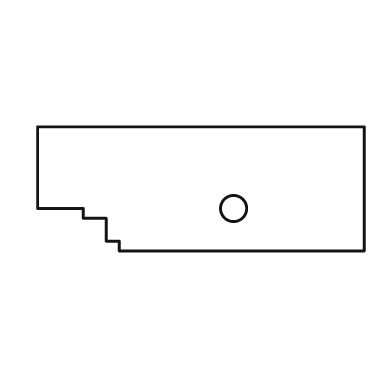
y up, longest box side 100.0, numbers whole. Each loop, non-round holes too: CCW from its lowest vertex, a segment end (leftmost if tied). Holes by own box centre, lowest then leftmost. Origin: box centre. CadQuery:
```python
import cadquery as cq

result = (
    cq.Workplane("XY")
    .moveTo(-25.0, -19.0)
    .lineTo(50.0, -19.0)
    .lineTo(50.0, 19.0)
    .lineTo(-50.0, 19.0)
    .lineTo(-50.0, -6.0)
    .lineTo(-36.0, -6.0)
    .lineTo(-36.0, -9.0)
    .lineTo(-29.0, -9.0)
    .lineTo(-29.0, -16.0)
    .lineTo(-25.0, -16.0)
    .close()
    .moveTo(10.0, -6.0)
    .circle(4.0)
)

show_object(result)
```